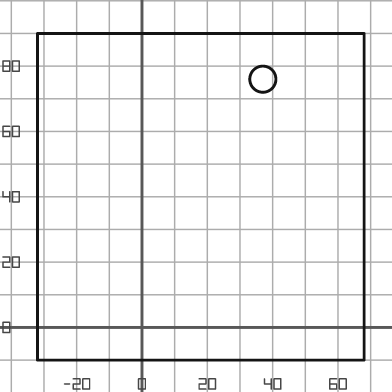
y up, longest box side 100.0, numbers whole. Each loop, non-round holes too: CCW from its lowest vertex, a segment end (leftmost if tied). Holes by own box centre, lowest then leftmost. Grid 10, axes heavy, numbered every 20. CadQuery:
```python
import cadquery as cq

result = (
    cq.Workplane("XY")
    .moveTo(-32.0, -10.0)
    .lineTo(68.0, -10.0)
    .lineTo(68.0, 90.0)
    .lineTo(-32.0, 90.0)
    .close()
    .moveTo(37.0, 76.0)
    .circle(4.0)
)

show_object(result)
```